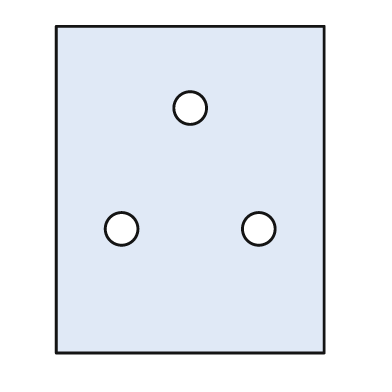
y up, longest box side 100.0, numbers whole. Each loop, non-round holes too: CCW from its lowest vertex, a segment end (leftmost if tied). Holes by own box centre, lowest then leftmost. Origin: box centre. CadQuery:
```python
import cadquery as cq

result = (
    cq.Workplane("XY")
    .moveTo(-41.0, -50.0)
    .lineTo(41.0, -50.0)
    .lineTo(41.0, 50.0)
    .lineTo(-41.0, 50.0)
    .close()
    .moveTo(-21.0, -12.0)
    .circle(5.0)
    .moveTo(21.0, -12.0)
    .circle(5.0)
    .moveTo(0.0, 25.0)
    .circle(5.0)
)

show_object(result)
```